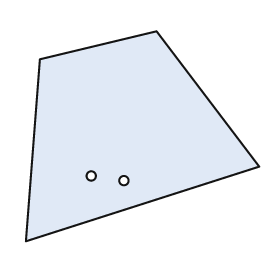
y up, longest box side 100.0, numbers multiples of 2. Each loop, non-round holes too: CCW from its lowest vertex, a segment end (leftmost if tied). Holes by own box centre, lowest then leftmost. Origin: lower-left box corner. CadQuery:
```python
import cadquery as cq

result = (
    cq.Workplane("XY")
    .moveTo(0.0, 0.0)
    .lineTo(100.0, 32.0)
    .lineTo(56.0, 90.0)
    .lineTo(6.0, 78.0)
    .close()
    .moveTo(42.0, 26.0)
    .circle(2.0)
    .moveTo(28.0, 28.0)
    .circle(2.0)
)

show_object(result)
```